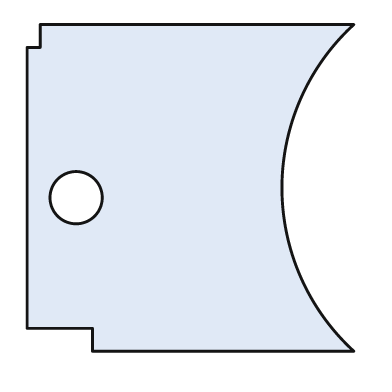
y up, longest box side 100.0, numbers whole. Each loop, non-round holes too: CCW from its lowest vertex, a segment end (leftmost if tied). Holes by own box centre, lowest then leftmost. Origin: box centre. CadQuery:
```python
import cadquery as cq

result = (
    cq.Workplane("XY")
    .moveTo(-30.0, -50.0)
    .lineTo(50.0, -50.0)
    .threePointArc((28.0, 0.0), (50.0, 50.0))
    .lineTo(-46.0, 50.0)
    .lineTo(-46.0, 43.0)
    .lineTo(-50.0, 43.0)
    .lineTo(-50.0, -43.0)
    .lineTo(-30.0, -43.0)
    .close()
    .moveTo(-35.0, -3.0)
    .circle(8.0)
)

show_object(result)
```